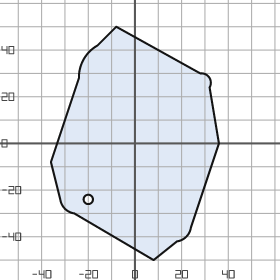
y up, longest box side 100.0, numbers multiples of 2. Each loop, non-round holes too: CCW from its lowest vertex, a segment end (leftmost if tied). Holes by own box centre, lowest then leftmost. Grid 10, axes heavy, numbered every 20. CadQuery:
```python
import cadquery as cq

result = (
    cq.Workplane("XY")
    .moveTo(8.0, -50.0)
    .lineTo(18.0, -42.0)
    .threePointArc((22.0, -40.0), (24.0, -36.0))
    .lineTo(36.0, 0.0)
    .lineTo(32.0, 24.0)
    .threePointArc((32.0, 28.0), (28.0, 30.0))
    .lineTo(-8.0, 50.0)
    .lineTo(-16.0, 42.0)
    .threePointArc((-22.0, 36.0), (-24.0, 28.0))
    .lineTo(-36.0, -8.0)
    .lineTo(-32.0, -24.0)
    .threePointArc((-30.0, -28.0), (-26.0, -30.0))
    .close()
    .moveTo(-20.0, -24.0)
    .circle(2.0)
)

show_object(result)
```